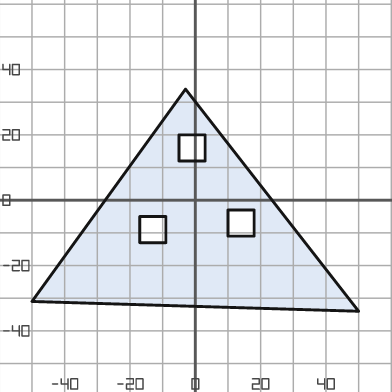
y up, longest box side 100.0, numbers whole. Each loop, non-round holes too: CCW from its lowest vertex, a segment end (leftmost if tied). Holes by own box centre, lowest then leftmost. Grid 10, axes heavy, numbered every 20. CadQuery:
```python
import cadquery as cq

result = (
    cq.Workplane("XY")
    .moveTo(50.0, -34.0)
    .lineTo(-3.0, 34.0)
    .lineTo(-50.0, -31.0)
    .close()
    .moveTo(-17.0, -13.0)
    .lineTo(-9.0, -13.0)
    .lineTo(-9.0, -5.0)
    .lineTo(-17.0, -5.0)
    .close()
    .moveTo(10.0, -11.0)
    .lineTo(18.0, -11.0)
    .lineTo(18.0, -3.0)
    .lineTo(10.0, -3.0)
    .close()
    .moveTo(-5.0, 12.0)
    .lineTo(3.0, 12.0)
    .lineTo(3.0, 20.0)
    .lineTo(-5.0, 20.0)
    .close()
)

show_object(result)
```